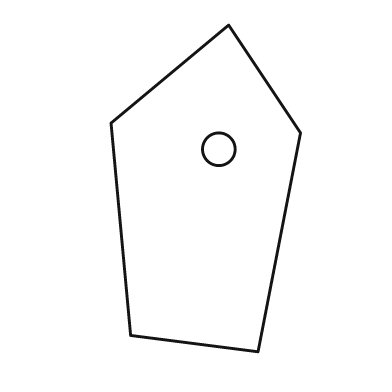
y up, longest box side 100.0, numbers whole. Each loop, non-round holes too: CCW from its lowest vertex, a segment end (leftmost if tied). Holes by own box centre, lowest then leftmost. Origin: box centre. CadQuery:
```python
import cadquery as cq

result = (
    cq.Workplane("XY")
    .moveTo(16.0, -50.0)
    .lineTo(29.0, 17.0)
    .lineTo(7.0, 50.0)
    .lineTo(-29.0, 20.0)
    .lineTo(-23.0, -45.0)
    .close()
    .moveTo(4.0, 12.0)
    .circle(5.0)
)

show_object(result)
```